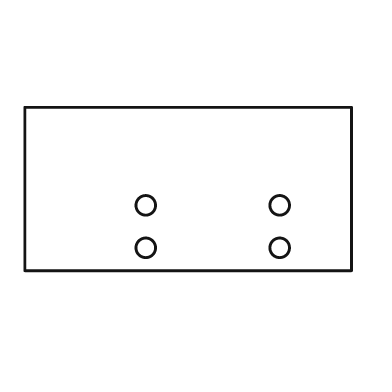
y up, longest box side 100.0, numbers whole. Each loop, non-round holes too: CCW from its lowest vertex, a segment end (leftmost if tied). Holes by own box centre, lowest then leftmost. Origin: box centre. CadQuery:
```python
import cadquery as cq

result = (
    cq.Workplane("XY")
    .moveTo(-50.0, -25.0)
    .lineTo(50.0, -25.0)
    .lineTo(50.0, 25.0)
    .lineTo(-50.0, 25.0)
    .close()
    .moveTo(-13.0, -18.0)
    .circle(3.0)
    .moveTo(28.0, -18.0)
    .circle(3.0)
    .moveTo(-13.0, -5.0)
    .circle(3.0)
    .moveTo(28.0, -5.0)
    .circle(3.0)
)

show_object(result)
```